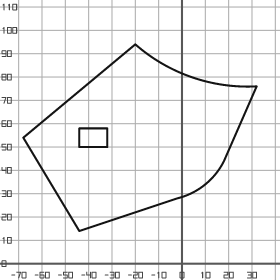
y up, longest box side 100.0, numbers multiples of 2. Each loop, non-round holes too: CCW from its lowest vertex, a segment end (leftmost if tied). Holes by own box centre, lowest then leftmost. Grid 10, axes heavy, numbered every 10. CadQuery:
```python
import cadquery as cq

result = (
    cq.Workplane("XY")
    .moveTo(-44.0, 14.0)
    .lineTo(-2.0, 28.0)
    .threePointArc((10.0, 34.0), (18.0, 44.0))
    .lineTo(32.0, 76.0)
    .threePointArc((4.0, 80.0), (-20.0, 94.0))
    .lineTo(-68.0, 54.0)
    .close()
    .moveTo(-44.0, 50.0)
    .lineTo(-32.0, 50.0)
    .lineTo(-32.0, 58.0)
    .lineTo(-44.0, 58.0)
    .close()
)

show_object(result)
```